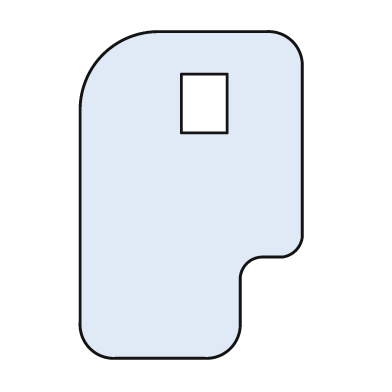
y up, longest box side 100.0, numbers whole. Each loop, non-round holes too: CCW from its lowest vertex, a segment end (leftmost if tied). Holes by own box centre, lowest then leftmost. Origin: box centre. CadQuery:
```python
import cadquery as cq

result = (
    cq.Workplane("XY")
    .moveTo(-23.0, -50.0)
    .lineTo(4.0, -50.0)
    .threePointArc((12.0, -47.0), (15.0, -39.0))
    .lineTo(15.0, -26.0)
    .threePointArc((17.0, -21.0), (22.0, -19.0))
    .lineTo(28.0, -19.0)
    .threePointArc((32.0, -17.0), (34.0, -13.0))
    .lineTo(34.0, 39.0)
    .threePointArc((31.0, 47.0), (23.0, 50.0))
    .lineTo(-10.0, 50.0)
    .threePointArc((-27.0, 43.0), (-34.0, 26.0))
    .lineTo(-34.0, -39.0)
    .threePointArc((-31.0, -47.0), (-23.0, -50.0))
    .close()
    .moveTo(-3.0, 19.0)
    .lineTo(11.0, 19.0)
    .lineTo(11.0, 37.0)
    .lineTo(-3.0, 37.0)
    .close()
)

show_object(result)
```